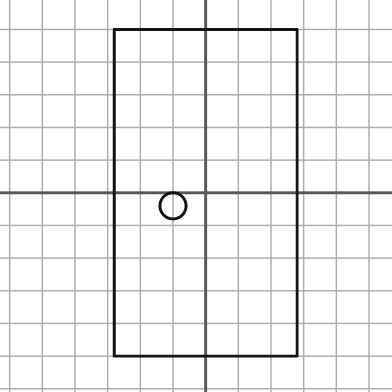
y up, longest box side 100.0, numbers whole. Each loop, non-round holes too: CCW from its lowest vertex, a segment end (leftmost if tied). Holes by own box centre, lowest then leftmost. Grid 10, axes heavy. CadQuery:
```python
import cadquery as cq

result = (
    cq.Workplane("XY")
    .moveTo(-28.0, -50.0)
    .lineTo(28.0, -50.0)
    .lineTo(28.0, 50.0)
    .lineTo(-28.0, 50.0)
    .close()
    .moveTo(-10.0, -4.0)
    .circle(4.0)
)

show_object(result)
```